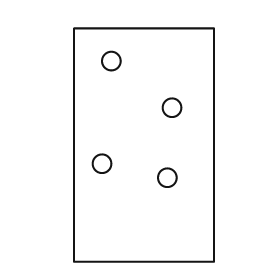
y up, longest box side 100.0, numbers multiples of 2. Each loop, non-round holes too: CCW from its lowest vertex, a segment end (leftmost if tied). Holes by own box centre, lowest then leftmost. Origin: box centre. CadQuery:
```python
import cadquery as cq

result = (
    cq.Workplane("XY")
    .moveTo(-30.0, -50.0)
    .lineTo(30.0, -50.0)
    .lineTo(30.0, 50.0)
    .lineTo(-30.0, 50.0)
    .close()
    .moveTo(10.0, -14.0)
    .circle(4.0)
    .moveTo(-18.0, -8.0)
    .circle(4.0)
    .moveTo(12.0, 16.0)
    .circle(4.0)
    .moveTo(-14.0, 36.0)
    .circle(4.0)
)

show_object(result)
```